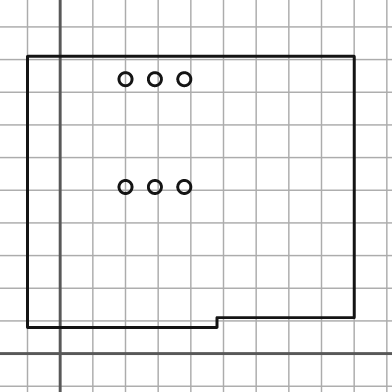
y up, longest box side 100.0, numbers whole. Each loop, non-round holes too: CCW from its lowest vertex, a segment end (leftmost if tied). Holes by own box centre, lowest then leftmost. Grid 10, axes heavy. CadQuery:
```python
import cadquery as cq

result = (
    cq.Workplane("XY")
    .moveTo(-10.0, 8.0)
    .lineTo(48.0, 8.0)
    .lineTo(48.0, 11.0)
    .lineTo(90.0, 11.0)
    .lineTo(90.0, 91.0)
    .lineTo(-10.0, 91.0)
    .close()
    .moveTo(20.0, 51.0)
    .circle(2.0)
    .moveTo(29.0, 51.0)
    .circle(2.0)
    .moveTo(38.0, 51.0)
    .circle(2.0)
    .moveTo(20.0, 84.0)
    .circle(2.0)
    .moveTo(29.0, 84.0)
    .circle(2.0)
    .moveTo(38.0, 84.0)
    .circle(2.0)
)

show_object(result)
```